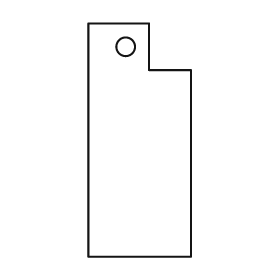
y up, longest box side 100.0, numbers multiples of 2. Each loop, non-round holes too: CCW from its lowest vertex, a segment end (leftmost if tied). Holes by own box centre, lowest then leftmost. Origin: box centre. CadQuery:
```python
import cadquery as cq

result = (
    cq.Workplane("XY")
    .moveTo(-22.0, -50.0)
    .lineTo(22.0, -50.0)
    .lineTo(22.0, 30.0)
    .lineTo(4.0, 30.0)
    .lineTo(4.0, 50.0)
    .lineTo(-22.0, 50.0)
    .close()
    .moveTo(-6.0, 40.0)
    .circle(4.0)
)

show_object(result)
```